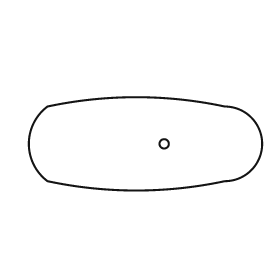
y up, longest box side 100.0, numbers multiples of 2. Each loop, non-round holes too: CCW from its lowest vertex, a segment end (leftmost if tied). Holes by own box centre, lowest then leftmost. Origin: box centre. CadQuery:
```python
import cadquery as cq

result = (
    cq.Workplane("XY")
    .moveTo(-42.0, -16.0)
    .threePointArc((-4.0, -20.0), (34.0, -16.0))
    .threePointArc((50.0, 0.0), (34.0, 16.0))
    .threePointArc((-4.0, 20.0), (-42.0, 16.0))
    .threePointArc((-50.0, 0.0), (-42.0, -16.0))
    .close()
    .moveTo(8.0, 0.0)
    .circle(2.0)
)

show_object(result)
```